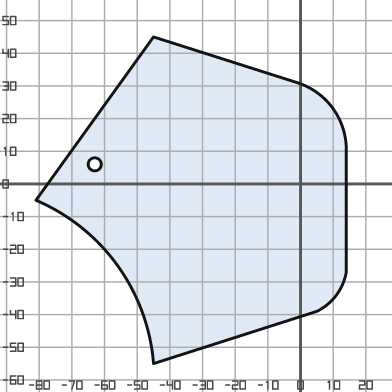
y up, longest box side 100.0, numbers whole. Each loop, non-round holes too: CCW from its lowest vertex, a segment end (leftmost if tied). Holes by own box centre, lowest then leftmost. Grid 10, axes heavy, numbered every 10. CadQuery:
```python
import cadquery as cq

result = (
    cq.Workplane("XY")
    .moveTo(-45.0, -55.0)
    .lineTo(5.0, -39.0)
    .threePointArc((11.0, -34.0), (14.0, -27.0))
    .lineTo(14.0, 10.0)
    .threePointArc((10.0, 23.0), (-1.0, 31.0))
    .lineTo(-45.0, 45.0)
    .lineTo(-81.0, -5.0)
    .threePointArc((-56.0, -25.0), (-45.0, -55.0))
    .close()
    .moveTo(-63.0, 6.0)
    .circle(2.0)
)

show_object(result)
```